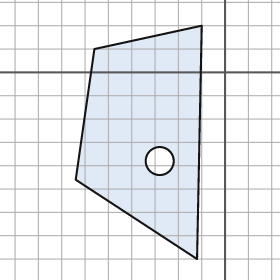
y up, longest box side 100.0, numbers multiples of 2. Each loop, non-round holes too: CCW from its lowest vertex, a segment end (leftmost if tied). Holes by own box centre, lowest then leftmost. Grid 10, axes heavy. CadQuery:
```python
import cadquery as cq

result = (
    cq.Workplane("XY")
    .moveTo(-12.0, -80.0)
    .lineTo(-10.0, 20.0)
    .lineTo(-56.0, 10.0)
    .lineTo(-64.0, -46.0)
    .close()
    .moveTo(-28.0, -38.0)
    .circle(6.0)
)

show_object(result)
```